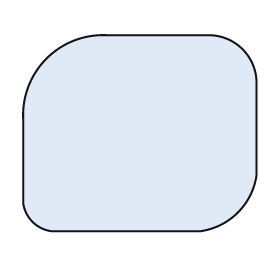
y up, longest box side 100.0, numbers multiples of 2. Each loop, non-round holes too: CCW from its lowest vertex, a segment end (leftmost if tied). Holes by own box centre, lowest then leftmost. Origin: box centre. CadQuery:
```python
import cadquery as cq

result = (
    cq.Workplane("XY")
    .moveTo(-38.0, -42.0)
    .lineTo(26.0, -42.0)
    .threePointArc((42.0, -34.0), (50.0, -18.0))
    .lineTo(50.0, 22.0)
    .threePointArc((44.0, 36.0), (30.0, 42.0))
    .lineTo(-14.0, 42.0)
    .threePointArc((-40.0, 32.0), (-50.0, 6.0))
    .lineTo(-50.0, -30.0)
    .threePointArc((-46.0, -38.0), (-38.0, -42.0))
    .close()
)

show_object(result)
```